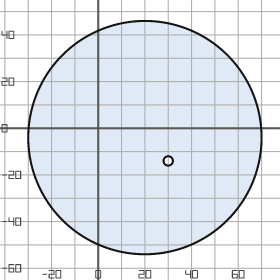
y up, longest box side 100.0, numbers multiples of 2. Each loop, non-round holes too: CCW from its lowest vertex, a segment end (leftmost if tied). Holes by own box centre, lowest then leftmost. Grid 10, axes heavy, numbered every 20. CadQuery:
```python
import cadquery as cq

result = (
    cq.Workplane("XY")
    .moveTo(20.0, -4.0)
    .circle(50.0)
    .moveTo(30.0, -14.0)
    .circle(2.0)
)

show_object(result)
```